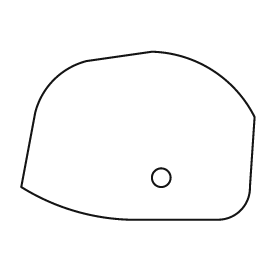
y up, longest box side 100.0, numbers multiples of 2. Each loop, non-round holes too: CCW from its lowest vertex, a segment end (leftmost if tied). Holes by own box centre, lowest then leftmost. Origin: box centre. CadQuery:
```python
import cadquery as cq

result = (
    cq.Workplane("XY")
    .moveTo(-4.0, -36.0)
    .lineTo(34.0, -36.0)
    .threePointArc((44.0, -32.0), (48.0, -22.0))
    .lineTo(50.0, 8.0)
    .threePointArc((32.0, 28.0), (6.0, 36.0))
    .lineTo(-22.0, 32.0)
    .threePointArc((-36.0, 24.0), (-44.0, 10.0))
    .lineTo(-50.0, -22.0)
    .threePointArc((-28.0, -32.0), (-4.0, -36.0))
    .close()
    .moveTo(10.0, -18.0)
    .circle(4.0)
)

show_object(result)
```